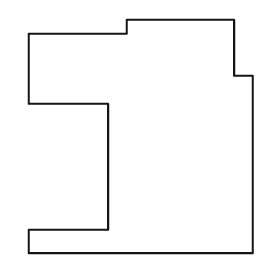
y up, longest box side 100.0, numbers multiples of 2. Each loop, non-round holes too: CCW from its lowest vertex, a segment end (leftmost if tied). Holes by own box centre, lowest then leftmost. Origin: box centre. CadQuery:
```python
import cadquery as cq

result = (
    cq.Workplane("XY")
    .moveTo(-48.0, -50.0)
    .lineTo(48.0, -50.0)
    .lineTo(48.0, 26.0)
    .lineTo(40.0, 26.0)
    .lineTo(40.0, 50.0)
    .lineTo(-6.0, 50.0)
    .lineTo(-6.0, 44.0)
    .lineTo(-48.0, 44.0)
    .lineTo(-48.0, 14.0)
    .lineTo(-14.0, 14.0)
    .lineTo(-14.0, -40.0)
    .lineTo(-48.0, -40.0)
    .close()
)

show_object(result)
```